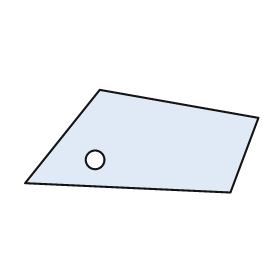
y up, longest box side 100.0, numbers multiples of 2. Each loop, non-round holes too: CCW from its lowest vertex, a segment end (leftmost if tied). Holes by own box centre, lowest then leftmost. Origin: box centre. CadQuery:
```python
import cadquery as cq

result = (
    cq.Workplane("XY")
    .moveTo(38.0, -22.0)
    .lineTo(50.0, 10.0)
    .lineTo(-18.0, 22.0)
    .lineTo(-50.0, -18.0)
    .close()
    .moveTo(-20.0, -8.0)
    .circle(4.0)
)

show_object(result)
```